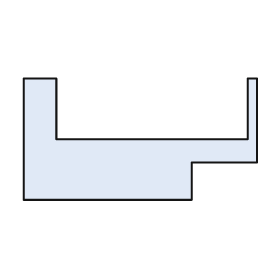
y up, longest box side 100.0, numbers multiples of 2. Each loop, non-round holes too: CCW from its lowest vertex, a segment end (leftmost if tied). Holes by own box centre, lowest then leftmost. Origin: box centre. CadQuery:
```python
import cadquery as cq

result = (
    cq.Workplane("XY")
    .moveTo(-50.0, -26.0)
    .lineTo(22.0, -26.0)
    .lineTo(22.0, -10.0)
    .lineTo(50.0, -10.0)
    .lineTo(50.0, 26.0)
    .lineTo(46.0, 26.0)
    .lineTo(46.0, 0.0)
    .lineTo(-36.0, 0.0)
    .lineTo(-36.0, 26.0)
    .lineTo(-50.0, 26.0)
    .close()
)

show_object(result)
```